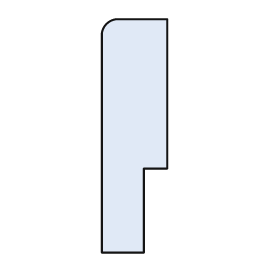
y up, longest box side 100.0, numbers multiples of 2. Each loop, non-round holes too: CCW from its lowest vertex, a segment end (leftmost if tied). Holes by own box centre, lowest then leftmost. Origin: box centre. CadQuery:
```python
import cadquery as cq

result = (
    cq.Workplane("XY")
    .moveTo(-14.0, -50.0)
    .lineTo(4.0, -50.0)
    .lineTo(4.0, -14.0)
    .lineTo(14.0, -14.0)
    .lineTo(14.0, 50.0)
    .lineTo(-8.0, 50.0)
    .threePointArc((-12.0, 48.0), (-14.0, 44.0))
    .close()
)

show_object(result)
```